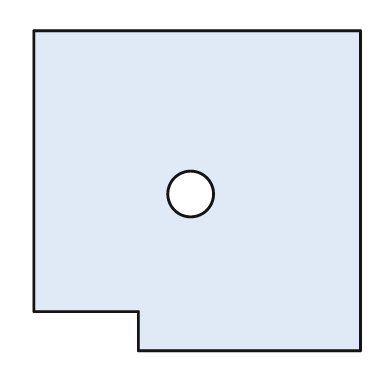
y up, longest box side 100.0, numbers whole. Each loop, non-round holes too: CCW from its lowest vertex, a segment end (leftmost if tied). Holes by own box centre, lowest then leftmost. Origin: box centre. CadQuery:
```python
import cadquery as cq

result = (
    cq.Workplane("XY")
    .moveTo(-18.0, -49.0)
    .lineTo(50.0, -49.0)
    .lineTo(50.0, 49.0)
    .lineTo(-50.0, 49.0)
    .lineTo(-50.0, -37.0)
    .lineTo(-18.0, -37.0)
    .close()
    .moveTo(-2.0, -1.0)
    .circle(7.0)
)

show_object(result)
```